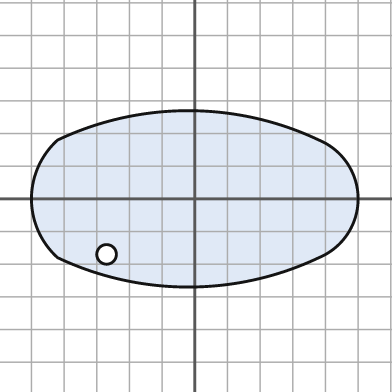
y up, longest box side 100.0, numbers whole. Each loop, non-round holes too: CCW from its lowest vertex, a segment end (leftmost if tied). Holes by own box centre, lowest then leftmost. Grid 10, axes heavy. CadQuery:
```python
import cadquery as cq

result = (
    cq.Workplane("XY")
    .moveTo(-42.0, -18.0)
    .threePointArc((-2.0, -27.0), (38.0, -18.0))
    .threePointArc((50.0, 0.0), (38.0, 18.0))
    .threePointArc((-2.0, 27.0), (-42.0, 18.0))
    .threePointArc((-50.0, 0.0), (-42.0, -18.0))
    .close()
    .moveTo(-27.0, -17.0)
    .circle(3.0)
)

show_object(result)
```